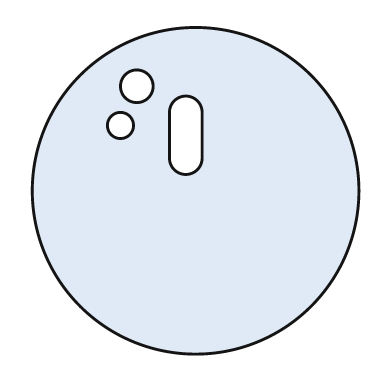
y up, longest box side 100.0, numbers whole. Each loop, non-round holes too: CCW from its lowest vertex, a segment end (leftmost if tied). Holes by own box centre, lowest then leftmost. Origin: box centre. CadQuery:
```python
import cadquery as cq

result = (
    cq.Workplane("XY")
    .moveTo(0.0, 0.0)
    .circle(50.0)
    .moveTo(-8.0, 10.0)
    .threePointArc((-3.0, 5.0), (2.0, 10.0))
    .lineTo(2.0, 24.0)
    .threePointArc((-3.0, 29.0), (-8.0, 24.0))
    .close()
    .moveTo(-23.0, 20.0)
    .circle(4.0)
    .moveTo(-18.0, 32.0)
    .circle(5.0)
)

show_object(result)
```